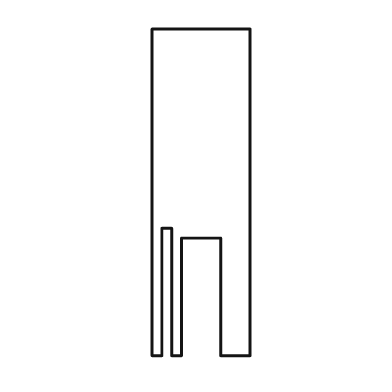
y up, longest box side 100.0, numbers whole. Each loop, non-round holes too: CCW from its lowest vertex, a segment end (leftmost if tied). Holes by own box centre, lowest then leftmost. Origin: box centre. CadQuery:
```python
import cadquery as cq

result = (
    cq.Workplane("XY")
    .moveTo(-15.0, -50.0)
    .lineTo(-12.0, -50.0)
    .lineTo(-12.0, -11.0)
    .lineTo(-9.0, -11.0)
    .lineTo(-9.0, -50.0)
    .lineTo(-6.0, -50.0)
    .lineTo(-6.0, -14.0)
    .lineTo(6.0, -14.0)
    .lineTo(6.0, -50.0)
    .lineTo(15.0, -50.0)
    .lineTo(15.0, 50.0)
    .lineTo(-15.0, 50.0)
    .close()
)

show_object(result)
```